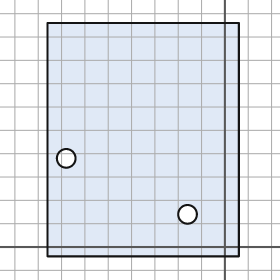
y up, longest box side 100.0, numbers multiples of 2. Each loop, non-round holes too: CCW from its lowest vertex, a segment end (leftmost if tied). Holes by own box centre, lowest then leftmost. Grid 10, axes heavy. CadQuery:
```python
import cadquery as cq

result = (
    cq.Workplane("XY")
    .moveTo(-76.0, -4.0)
    .lineTo(6.0, -4.0)
    .lineTo(6.0, 96.0)
    .lineTo(-76.0, 96.0)
    .close()
    .moveTo(-16.0, 14.0)
    .circle(4.0)
    .moveTo(-68.0, 38.0)
    .circle(4.0)
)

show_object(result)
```